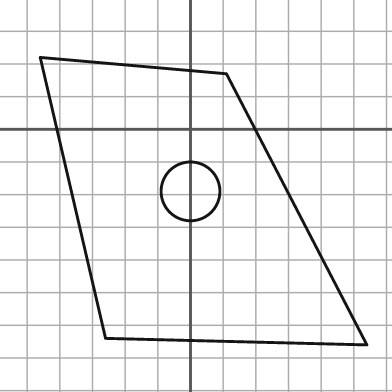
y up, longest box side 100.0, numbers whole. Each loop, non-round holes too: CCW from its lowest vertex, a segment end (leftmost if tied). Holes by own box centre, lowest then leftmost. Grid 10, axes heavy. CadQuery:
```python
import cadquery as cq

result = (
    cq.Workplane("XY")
    .moveTo(54.0, -66.0)
    .lineTo(11.0, 17.0)
    .lineTo(-46.0, 22.0)
    .lineTo(-26.0, -64.0)
    .close()
    .moveTo(0.0, -19.0)
    .circle(9.0)
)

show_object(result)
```